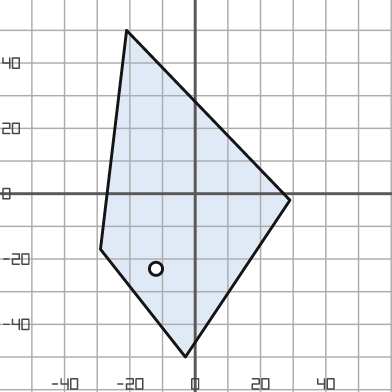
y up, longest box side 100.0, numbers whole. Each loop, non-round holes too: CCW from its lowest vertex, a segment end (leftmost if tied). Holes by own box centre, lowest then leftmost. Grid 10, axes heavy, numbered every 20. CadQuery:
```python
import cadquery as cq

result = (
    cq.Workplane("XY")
    .moveTo(-3.0, -50.0)
    .lineTo(29.0, -2.0)
    .lineTo(-21.0, 50.0)
    .lineTo(-29.0, -17.0)
    .close()
    .moveTo(-12.0, -23.0)
    .circle(2.0)
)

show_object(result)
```